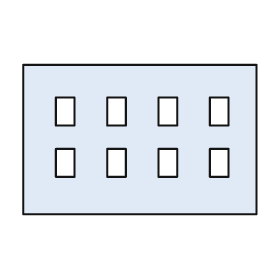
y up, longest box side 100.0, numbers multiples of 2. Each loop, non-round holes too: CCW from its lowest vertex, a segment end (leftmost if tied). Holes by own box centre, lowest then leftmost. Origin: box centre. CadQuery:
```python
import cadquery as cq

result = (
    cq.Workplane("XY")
    .moveTo(-50.0, -32.0)
    .lineTo(50.0, -32.0)
    .lineTo(50.0, 32.0)
    .lineTo(-50.0, 32.0)
    .close()
    .moveTo(-36.0, -16.0)
    .lineTo(-28.0, -16.0)
    .lineTo(-28.0, -4.0)
    .lineTo(-36.0, -4.0)
    .close()
    .moveTo(-14.0, -16.0)
    .lineTo(-6.0, -16.0)
    .lineTo(-6.0, -4.0)
    .lineTo(-14.0, -4.0)
    .close()
    .moveTo(8.0, -16.0)
    .lineTo(16.0, -16.0)
    .lineTo(16.0, -4.0)
    .lineTo(8.0, -4.0)
    .close()
    .moveTo(30.0, -16.0)
    .lineTo(38.0, -16.0)
    .lineTo(38.0, -4.0)
    .lineTo(30.0, -4.0)
    .close()
    .moveTo(-36.0, 6.0)
    .lineTo(-28.0, 6.0)
    .lineTo(-28.0, 18.0)
    .lineTo(-36.0, 18.0)
    .close()
    .moveTo(-14.0, 6.0)
    .lineTo(-6.0, 6.0)
    .lineTo(-6.0, 18.0)
    .lineTo(-14.0, 18.0)
    .close()
    .moveTo(8.0, 6.0)
    .lineTo(16.0, 6.0)
    .lineTo(16.0, 18.0)
    .lineTo(8.0, 18.0)
    .close()
    .moveTo(30.0, 6.0)
    .lineTo(38.0, 6.0)
    .lineTo(38.0, 18.0)
    .lineTo(30.0, 18.0)
    .close()
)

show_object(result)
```